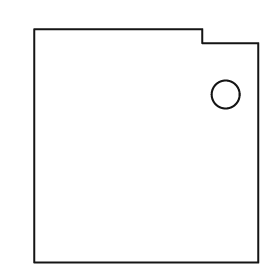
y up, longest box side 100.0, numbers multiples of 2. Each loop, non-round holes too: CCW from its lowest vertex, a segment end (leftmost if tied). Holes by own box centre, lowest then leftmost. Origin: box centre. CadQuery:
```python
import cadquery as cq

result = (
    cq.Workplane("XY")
    .moveTo(-48.0, -50.0)
    .lineTo(48.0, -50.0)
    .lineTo(48.0, 44.0)
    .lineTo(24.0, 44.0)
    .lineTo(24.0, 50.0)
    .lineTo(-48.0, 50.0)
    .close()
    .moveTo(34.0, 22.0)
    .circle(6.0)
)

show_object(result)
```